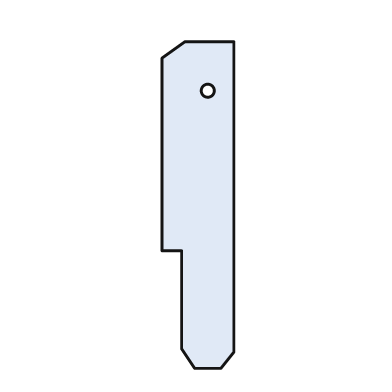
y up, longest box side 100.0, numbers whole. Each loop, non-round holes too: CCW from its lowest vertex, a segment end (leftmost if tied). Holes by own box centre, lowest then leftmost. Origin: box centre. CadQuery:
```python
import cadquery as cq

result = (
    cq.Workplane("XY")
    .moveTo(-1.0, -50.0)
    .lineTo(7.0, -50.0)
    .lineTo(11.0, -45.0)
    .lineTo(11.0, 50.0)
    .lineTo(-4.0, 50.0)
    .lineTo(-11.0, 45.0)
    .lineTo(-11.0, -14.0)
    .lineTo(-5.0, -14.0)
    .lineTo(-5.0, -44.0)
    .close()
    .moveTo(3.0, 35.0)
    .circle(2.0)
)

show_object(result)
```